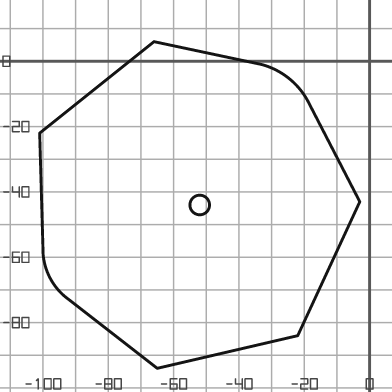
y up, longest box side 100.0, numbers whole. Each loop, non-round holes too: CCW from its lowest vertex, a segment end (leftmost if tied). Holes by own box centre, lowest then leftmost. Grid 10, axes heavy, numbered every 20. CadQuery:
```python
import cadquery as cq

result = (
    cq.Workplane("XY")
    .moveTo(-65.0, -94.0)
    .lineTo(-22.0, -84.0)
    .lineTo(-3.0, -43.0)
    .lineTo(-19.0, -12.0)
    .threePointArc((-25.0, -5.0), (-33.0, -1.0))
    .lineTo(-66.0, 6.0)
    .lineTo(-101.0, -22.0)
    .lineTo(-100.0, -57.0)
    .threePointArc((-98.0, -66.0), (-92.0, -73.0))
    .close()
    .moveTo(-52.0, -44.0)
    .circle(3.0)
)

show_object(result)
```